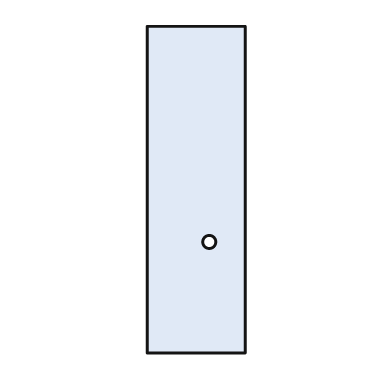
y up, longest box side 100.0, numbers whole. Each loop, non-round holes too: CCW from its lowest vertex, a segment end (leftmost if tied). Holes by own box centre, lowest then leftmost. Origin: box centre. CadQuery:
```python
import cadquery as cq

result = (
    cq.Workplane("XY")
    .moveTo(-15.0, -50.0)
    .lineTo(15.0, -50.0)
    .lineTo(15.0, 50.0)
    .lineTo(-15.0, 50.0)
    .close()
    .moveTo(4.0, -16.0)
    .circle(2.0)
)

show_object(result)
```